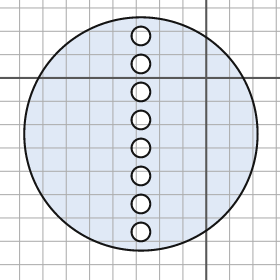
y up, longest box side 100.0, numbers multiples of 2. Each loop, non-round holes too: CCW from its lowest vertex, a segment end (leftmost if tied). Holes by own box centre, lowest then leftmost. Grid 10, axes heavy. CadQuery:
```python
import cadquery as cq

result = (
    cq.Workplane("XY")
    .moveTo(-28.0, -24.0)
    .circle(50.0)
    .moveTo(-28.0, -66.0)
    .circle(4.0)
    .moveTo(-28.0, -54.0)
    .circle(4.0)
    .moveTo(-28.0, -42.0)
    .circle(4.0)
    .moveTo(-28.0, -30.0)
    .circle(4.0)
    .moveTo(-28.0, -18.0)
    .circle(4.0)
    .moveTo(-28.0, -6.0)
    .circle(4.0)
    .moveTo(-28.0, 6.0)
    .circle(4.0)
    .moveTo(-28.0, 18.0)
    .circle(4.0)
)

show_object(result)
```